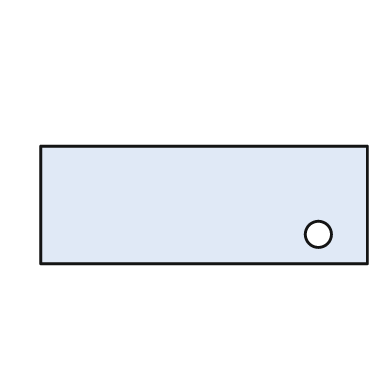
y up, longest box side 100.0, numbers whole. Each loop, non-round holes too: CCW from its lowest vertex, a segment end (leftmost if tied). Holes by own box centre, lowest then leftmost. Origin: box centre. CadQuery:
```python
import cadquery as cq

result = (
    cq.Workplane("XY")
    .moveTo(-50.0, -18.0)
    .lineTo(50.0, -18.0)
    .lineTo(50.0, 18.0)
    .lineTo(-50.0, 18.0)
    .close()
    .moveTo(35.0, -9.0)
    .circle(4.0)
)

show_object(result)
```